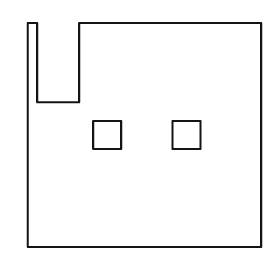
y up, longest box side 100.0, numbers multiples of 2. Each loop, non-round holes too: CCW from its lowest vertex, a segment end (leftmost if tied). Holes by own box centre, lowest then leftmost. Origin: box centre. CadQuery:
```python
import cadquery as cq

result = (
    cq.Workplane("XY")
    .moveTo(-50.0, -48.0)
    .lineTo(50.0, -48.0)
    .lineTo(50.0, 48.0)
    .lineTo(-28.0, 48.0)
    .lineTo(-28.0, 14.0)
    .lineTo(-46.0, 14.0)
    .lineTo(-46.0, 48.0)
    .lineTo(-50.0, 48.0)
    .close()
    .moveTo(-22.0, -6.0)
    .lineTo(-10.0, -6.0)
    .lineTo(-10.0, 6.0)
    .lineTo(-22.0, 6.0)
    .close()
    .moveTo(12.0, -6.0)
    .lineTo(24.0, -6.0)
    .lineTo(24.0, 6.0)
    .lineTo(12.0, 6.0)
    .close()
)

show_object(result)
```